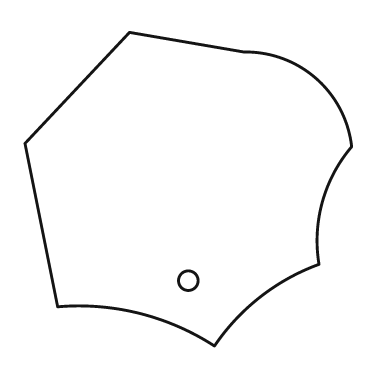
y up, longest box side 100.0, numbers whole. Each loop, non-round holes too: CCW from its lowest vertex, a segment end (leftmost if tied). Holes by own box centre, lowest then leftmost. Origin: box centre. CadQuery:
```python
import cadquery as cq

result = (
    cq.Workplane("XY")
    .moveTo(8.0, -48.0)
    .threePointArc((22.0, -33.0), (40.0, -23.0))
    .threePointArc((41.0, -4.0), (50.0, 13.0))
    .threePointArc((39.0, 34.0), (17.0, 42.0))
    .lineTo(-18.0, 48.0)
    .lineTo(-50.0, 14.0)
    .lineTo(-40.0, -36.0)
    .threePointArc((-15.0, -38.0), (8.0, -48.0))
    .close()
    .moveTo(0.0, -28.0)
    .circle(3.0)
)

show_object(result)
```